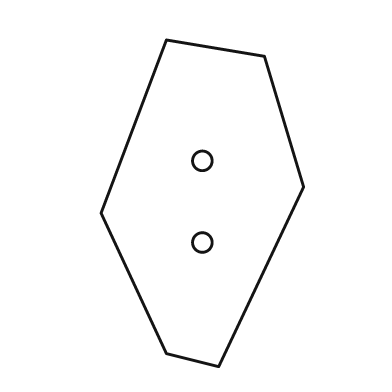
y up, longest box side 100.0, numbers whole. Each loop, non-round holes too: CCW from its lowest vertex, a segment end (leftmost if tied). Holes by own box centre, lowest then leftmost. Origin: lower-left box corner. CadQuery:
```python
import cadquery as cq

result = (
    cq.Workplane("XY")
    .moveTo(36.0, 0.0)
    .lineTo(62.0, 55.0)
    .lineTo(50.0, 95.0)
    .lineTo(20.0, 100.0)
    .lineTo(0.0, 47.0)
    .lineTo(20.0, 4.0)
    .close()
    .moveTo(31.0, 38.0)
    .circle(3.0)
    .moveTo(31.0, 63.0)
    .circle(3.0)
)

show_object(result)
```